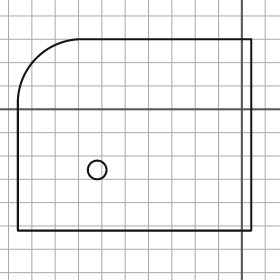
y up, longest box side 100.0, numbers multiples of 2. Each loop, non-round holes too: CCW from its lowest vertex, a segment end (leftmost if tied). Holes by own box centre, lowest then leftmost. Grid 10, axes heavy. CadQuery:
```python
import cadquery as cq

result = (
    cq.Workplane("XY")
    .moveTo(-96.0, -52.0)
    .lineTo(4.0, -52.0)
    .lineTo(4.0, 30.0)
    .lineTo(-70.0, 30.0)
    .threePointArc((-88.0, 22.0), (-96.0, 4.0))
    .close()
    .moveTo(-62.0, -26.0)
    .circle(4.0)
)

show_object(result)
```